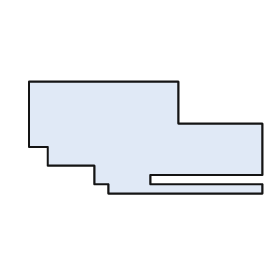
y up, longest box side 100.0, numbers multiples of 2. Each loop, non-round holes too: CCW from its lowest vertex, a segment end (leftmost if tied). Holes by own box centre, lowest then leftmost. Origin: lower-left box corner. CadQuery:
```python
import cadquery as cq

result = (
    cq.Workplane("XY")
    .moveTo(34.0, 0.0)
    .lineTo(100.0, 0.0)
    .lineTo(100.0, 4.0)
    .lineTo(52.0, 4.0)
    .lineTo(52.0, 8.0)
    .lineTo(100.0, 8.0)
    .lineTo(100.0, 30.0)
    .lineTo(64.0, 30.0)
    .lineTo(64.0, 48.0)
    .lineTo(0.0, 48.0)
    .lineTo(0.0, 20.0)
    .lineTo(8.0, 20.0)
    .lineTo(8.0, 12.0)
    .lineTo(28.0, 12.0)
    .lineTo(28.0, 4.0)
    .lineTo(34.0, 4.0)
    .close()
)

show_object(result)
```